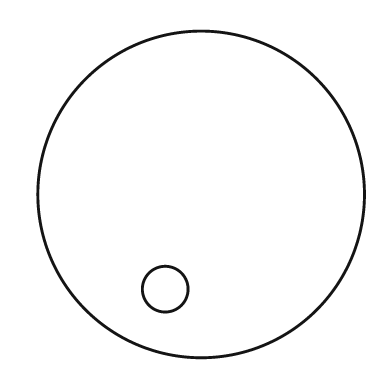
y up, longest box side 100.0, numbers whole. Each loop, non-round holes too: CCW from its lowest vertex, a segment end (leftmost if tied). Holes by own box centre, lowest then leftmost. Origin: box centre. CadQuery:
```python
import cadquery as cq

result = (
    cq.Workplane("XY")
    .moveTo(0.0, 0.0)
    .circle(50.0)
    .moveTo(-11.0, -29.0)
    .circle(7.0)
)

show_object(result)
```